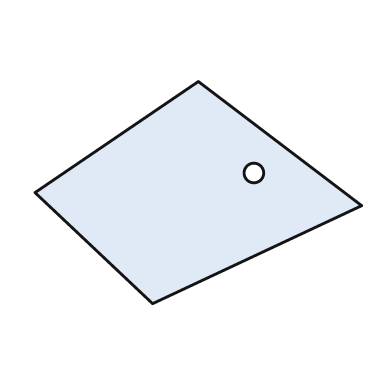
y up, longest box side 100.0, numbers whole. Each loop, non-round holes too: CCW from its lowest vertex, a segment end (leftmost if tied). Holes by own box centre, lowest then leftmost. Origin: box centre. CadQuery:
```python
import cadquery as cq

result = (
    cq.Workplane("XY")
    .moveTo(-14.0, -34.0)
    .lineTo(50.0, -4.0)
    .lineTo(0.0, 34.0)
    .lineTo(-50.0, 0.0)
    .close()
    .moveTo(17.0, 6.0)
    .circle(3.0)
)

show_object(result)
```